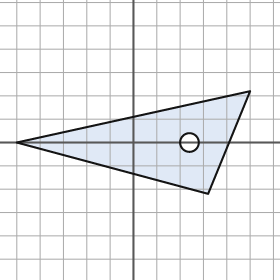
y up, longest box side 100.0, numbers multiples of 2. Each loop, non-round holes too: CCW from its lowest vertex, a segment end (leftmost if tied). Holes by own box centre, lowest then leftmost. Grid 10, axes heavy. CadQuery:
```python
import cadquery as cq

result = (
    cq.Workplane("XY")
    .moveTo(32.0, -22.0)
    .lineTo(50.0, 22.0)
    .lineTo(-50.0, 0.0)
    .close()
    .moveTo(24.0, 0.0)
    .circle(4.0)
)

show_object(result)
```